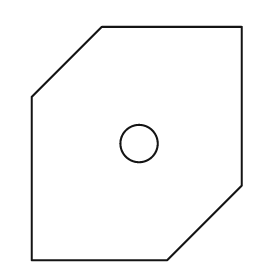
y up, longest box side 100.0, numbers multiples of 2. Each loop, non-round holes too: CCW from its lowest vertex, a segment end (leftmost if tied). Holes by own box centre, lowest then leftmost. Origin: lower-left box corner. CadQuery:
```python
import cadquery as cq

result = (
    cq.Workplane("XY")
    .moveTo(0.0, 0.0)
    .lineTo(58.0, 0.0)
    .lineTo(90.0, 32.0)
    .lineTo(90.0, 100.0)
    .lineTo(30.0, 100.0)
    .lineTo(0.0, 70.0)
    .close()
    .moveTo(46.0, 50.0)
    .circle(8.0)
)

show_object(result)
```